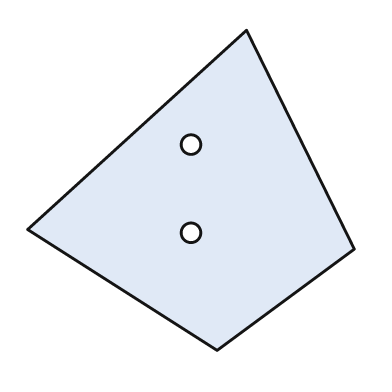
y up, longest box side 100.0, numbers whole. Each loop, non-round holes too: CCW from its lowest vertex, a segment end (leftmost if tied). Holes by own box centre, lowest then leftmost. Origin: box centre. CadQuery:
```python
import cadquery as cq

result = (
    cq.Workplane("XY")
    .moveTo(8.0, -49.0)
    .lineTo(50.0, -18.0)
    .lineTo(17.0, 49.0)
    .lineTo(-50.0, -12.0)
    .close()
    .moveTo(0.0, -13.0)
    .circle(3.0)
    .moveTo(0.0, 14.0)
    .circle(3.0)
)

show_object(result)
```